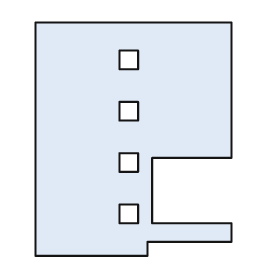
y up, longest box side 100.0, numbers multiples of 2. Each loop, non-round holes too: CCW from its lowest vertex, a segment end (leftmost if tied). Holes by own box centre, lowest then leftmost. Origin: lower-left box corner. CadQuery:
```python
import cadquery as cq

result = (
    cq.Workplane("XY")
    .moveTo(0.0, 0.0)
    .lineTo(48.0, 0.0)
    .lineTo(48.0, 6.0)
    .lineTo(84.0, 6.0)
    .lineTo(84.0, 14.0)
    .lineTo(50.0, 14.0)
    .lineTo(50.0, 42.0)
    .lineTo(84.0, 42.0)
    .lineTo(84.0, 100.0)
    .lineTo(0.0, 100.0)
    .close()
    .moveTo(36.0, 14.0)
    .lineTo(44.0, 14.0)
    .lineTo(44.0, 22.0)
    .lineTo(36.0, 22.0)
    .close()
    .moveTo(36.0, 36.0)
    .lineTo(44.0, 36.0)
    .lineTo(44.0, 44.0)
    .lineTo(36.0, 44.0)
    .close()
    .moveTo(36.0, 58.0)
    .lineTo(44.0, 58.0)
    .lineTo(44.0, 66.0)
    .lineTo(36.0, 66.0)
    .close()
    .moveTo(36.0, 80.0)
    .lineTo(44.0, 80.0)
    .lineTo(44.0, 88.0)
    .lineTo(36.0, 88.0)
    .close()
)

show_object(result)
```